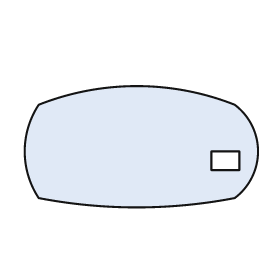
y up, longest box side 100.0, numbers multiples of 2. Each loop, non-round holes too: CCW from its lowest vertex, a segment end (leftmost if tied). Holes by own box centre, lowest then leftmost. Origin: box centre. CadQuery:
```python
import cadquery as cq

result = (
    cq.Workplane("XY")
    .moveTo(-44.0, -22.0)
    .threePointArc((-2.0, -26.0), (40.0, -22.0))
    .threePointArc((50.0, -2.0), (40.0, 18.0))
    .threePointArc((-2.0, 26.0), (-44.0, 18.0))
    .threePointArc((-50.0, -2.0), (-44.0, -22.0))
    .close()
    .moveTo(30.0, -10.0)
    .lineTo(42.0, -10.0)
    .lineTo(42.0, -2.0)
    .lineTo(30.0, -2.0)
    .close()
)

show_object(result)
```